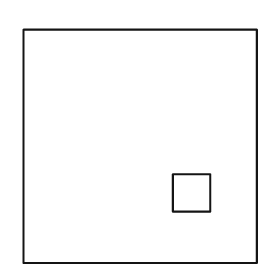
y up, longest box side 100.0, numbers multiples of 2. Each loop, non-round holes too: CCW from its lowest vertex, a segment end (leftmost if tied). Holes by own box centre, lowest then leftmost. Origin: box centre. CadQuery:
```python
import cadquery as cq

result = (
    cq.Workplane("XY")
    .moveTo(-50.0, -50.0)
    .lineTo(50.0, -50.0)
    .lineTo(50.0, 50.0)
    .lineTo(-50.0, 50.0)
    .close()
    .moveTo(14.0, -28.0)
    .lineTo(30.0, -28.0)
    .lineTo(30.0, -12.0)
    .lineTo(14.0, -12.0)
    .close()
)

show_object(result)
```